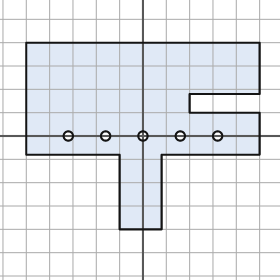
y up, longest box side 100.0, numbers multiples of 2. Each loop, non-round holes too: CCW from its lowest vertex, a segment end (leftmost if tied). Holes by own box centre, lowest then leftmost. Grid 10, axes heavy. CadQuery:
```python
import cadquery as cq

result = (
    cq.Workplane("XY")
    .moveTo(-10.0, -40.0)
    .lineTo(8.0, -40.0)
    .lineTo(8.0, -8.0)
    .lineTo(50.0, -8.0)
    .lineTo(50.0, 10.0)
    .lineTo(20.0, 10.0)
    .lineTo(20.0, 18.0)
    .lineTo(50.0, 18.0)
    .lineTo(50.0, 40.0)
    .lineTo(-50.0, 40.0)
    .lineTo(-50.0, -8.0)
    .lineTo(-10.0, -8.0)
    .close()
    .moveTo(-32.0, 0.0)
    .circle(2.0)
    .moveTo(-16.0, 0.0)
    .circle(2.0)
    .moveTo(0.0, 0.0)
    .circle(2.0)
    .moveTo(16.0, 0.0)
    .circle(2.0)
    .moveTo(32.0, 0.0)
    .circle(2.0)
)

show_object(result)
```